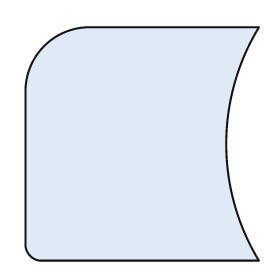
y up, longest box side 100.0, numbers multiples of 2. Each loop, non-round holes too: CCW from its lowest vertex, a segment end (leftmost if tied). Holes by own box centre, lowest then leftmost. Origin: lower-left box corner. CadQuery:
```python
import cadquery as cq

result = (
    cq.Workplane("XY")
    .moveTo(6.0, 0.0)
    .lineTo(100.0, 0.0)
    .threePointArc((86.0, 50.0), (100.0, 100.0))
    .lineTo(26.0, 100.0)
    .threePointArc((8.0, 92.0), (0.0, 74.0))
    .lineTo(0.0, 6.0)
    .threePointArc((2.0, 2.0), (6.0, 0.0))
    .close()
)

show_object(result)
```